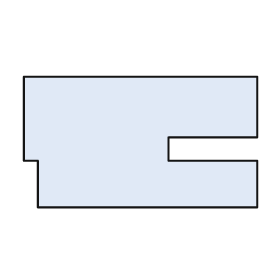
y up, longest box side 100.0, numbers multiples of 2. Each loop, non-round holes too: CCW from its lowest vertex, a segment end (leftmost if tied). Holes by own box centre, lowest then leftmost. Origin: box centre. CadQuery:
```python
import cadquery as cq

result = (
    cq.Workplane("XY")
    .moveTo(-44.0, -28.0)
    .lineTo(50.0, -28.0)
    .lineTo(50.0, -8.0)
    .lineTo(12.0, -8.0)
    .lineTo(12.0, 2.0)
    .lineTo(50.0, 2.0)
    .lineTo(50.0, 28.0)
    .lineTo(-50.0, 28.0)
    .lineTo(-50.0, -8.0)
    .lineTo(-44.0, -8.0)
    .close()
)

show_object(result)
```